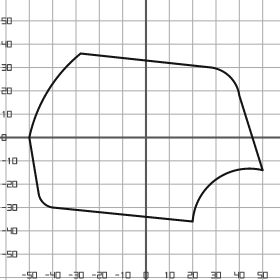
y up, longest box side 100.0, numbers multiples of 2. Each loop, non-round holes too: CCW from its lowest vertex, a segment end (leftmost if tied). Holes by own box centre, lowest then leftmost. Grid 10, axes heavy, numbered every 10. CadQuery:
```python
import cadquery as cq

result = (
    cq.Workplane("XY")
    .moveTo(20.0, -36.0)
    .threePointArc((30.0, -18.0), (50.0, -14.0))
    .lineTo(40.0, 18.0)
    .threePointArc((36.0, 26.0), (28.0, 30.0))
    .lineTo(-28.0, 36.0)
    .threePointArc((-42.0, 20.0), (-50.0, 0.0))
    .lineTo(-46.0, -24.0)
    .threePointArc((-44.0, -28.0), (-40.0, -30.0))
    .close()
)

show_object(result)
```